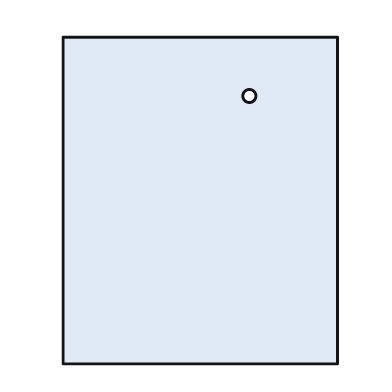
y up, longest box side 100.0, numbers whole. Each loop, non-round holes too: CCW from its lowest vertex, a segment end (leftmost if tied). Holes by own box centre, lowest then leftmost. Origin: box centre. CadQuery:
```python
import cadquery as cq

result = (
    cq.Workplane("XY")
    .moveTo(-42.0, -50.0)
    .lineTo(42.0, -50.0)
    .lineTo(42.0, 50.0)
    .lineTo(-42.0, 50.0)
    .close()
    .moveTo(15.0, 32.0)
    .circle(2.0)
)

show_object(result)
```